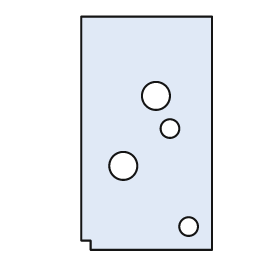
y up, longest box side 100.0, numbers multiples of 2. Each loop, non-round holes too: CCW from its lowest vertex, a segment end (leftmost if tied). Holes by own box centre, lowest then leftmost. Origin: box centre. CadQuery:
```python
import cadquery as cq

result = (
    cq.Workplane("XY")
    .moveTo(-24.0, -50.0)
    .lineTo(28.0, -50.0)
    .lineTo(28.0, 50.0)
    .lineTo(-28.0, 50.0)
    .lineTo(-28.0, -46.0)
    .lineTo(-24.0, -46.0)
    .close()
    .moveTo(18.0, -40.0)
    .circle(4.0)
    .moveTo(-10.0, -14.0)
    .circle(6.0)
    .moveTo(10.0, 2.0)
    .circle(4.0)
    .moveTo(4.0, 16.0)
    .circle(6.0)
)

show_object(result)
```